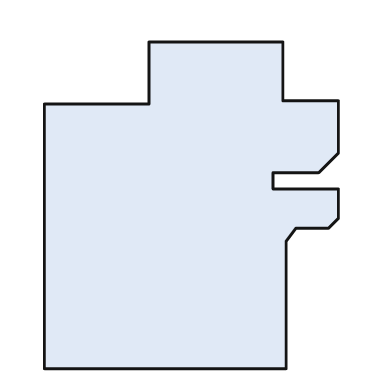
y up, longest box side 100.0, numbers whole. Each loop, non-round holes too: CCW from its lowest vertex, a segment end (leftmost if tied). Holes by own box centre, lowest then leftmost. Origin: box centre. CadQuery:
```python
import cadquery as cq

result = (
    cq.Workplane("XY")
    .moveTo(-45.0, -50.0)
    .lineTo(29.0, -50.0)
    .lineTo(29.0, -11.0)
    .lineTo(32.0, -7.0)
    .lineTo(42.0, -7.0)
    .lineTo(45.0, -4.0)
    .lineTo(45.0, 5.0)
    .lineTo(25.0, 5.0)
    .lineTo(25.0, 10.0)
    .lineTo(39.0, 10.0)
    .lineTo(45.0, 16.0)
    .lineTo(45.0, 32.0)
    .lineTo(28.0, 32.0)
    .lineTo(28.0, 50.0)
    .lineTo(-13.0, 50.0)
    .lineTo(-13.0, 31.0)
    .lineTo(-45.0, 31.0)
    .close()
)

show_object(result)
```